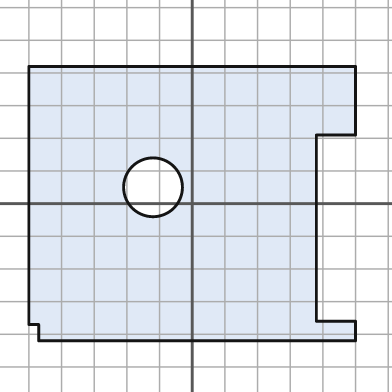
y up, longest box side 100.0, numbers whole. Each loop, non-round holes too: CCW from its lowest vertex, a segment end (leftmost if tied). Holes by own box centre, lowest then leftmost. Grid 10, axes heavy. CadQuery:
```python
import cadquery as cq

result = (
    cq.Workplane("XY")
    .moveTo(-47.0, -42.0)
    .lineTo(50.0, -42.0)
    .lineTo(50.0, -36.0)
    .lineTo(38.0, -36.0)
    .lineTo(38.0, 21.0)
    .lineTo(50.0, 21.0)
    .lineTo(50.0, 42.0)
    .lineTo(-50.0, 42.0)
    .lineTo(-50.0, -37.0)
    .lineTo(-47.0, -37.0)
    .close()
    .moveTo(-12.0, 5.0)
    .circle(9.0)
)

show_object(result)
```